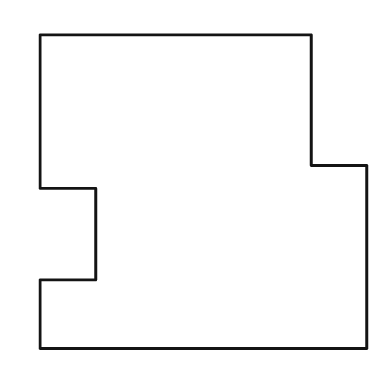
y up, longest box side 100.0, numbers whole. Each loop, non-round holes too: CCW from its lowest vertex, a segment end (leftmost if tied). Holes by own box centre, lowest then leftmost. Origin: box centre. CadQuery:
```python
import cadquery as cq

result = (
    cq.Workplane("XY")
    .moveTo(-50.0, -48.0)
    .lineTo(50.0, -48.0)
    .lineTo(50.0, 8.0)
    .lineTo(33.0, 8.0)
    .lineTo(33.0, 48.0)
    .lineTo(-50.0, 48.0)
    .lineTo(-50.0, 1.0)
    .lineTo(-33.0, 1.0)
    .lineTo(-33.0, -27.0)
    .lineTo(-50.0, -27.0)
    .close()
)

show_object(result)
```